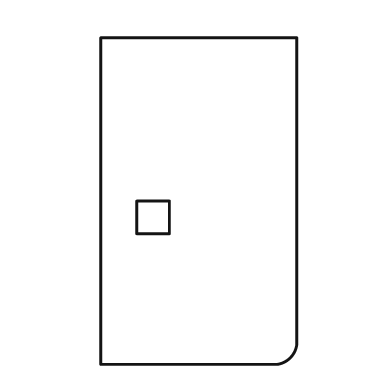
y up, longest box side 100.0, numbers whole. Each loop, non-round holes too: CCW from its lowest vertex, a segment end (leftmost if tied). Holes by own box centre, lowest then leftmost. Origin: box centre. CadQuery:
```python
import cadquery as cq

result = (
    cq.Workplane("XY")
    .moveTo(-30.0, -50.0)
    .lineTo(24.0, -50.0)
    .threePointArc((28.0, -48.0), (30.0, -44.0))
    .lineTo(30.0, 50.0)
    .lineTo(-30.0, 50.0)
    .close()
    .moveTo(-19.0, -10.0)
    .lineTo(-9.0, -10.0)
    .lineTo(-9.0, 0.0)
    .lineTo(-19.0, 0.0)
    .close()
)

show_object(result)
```